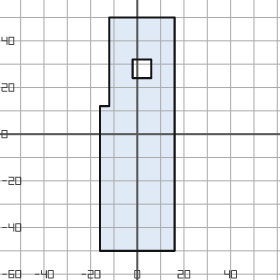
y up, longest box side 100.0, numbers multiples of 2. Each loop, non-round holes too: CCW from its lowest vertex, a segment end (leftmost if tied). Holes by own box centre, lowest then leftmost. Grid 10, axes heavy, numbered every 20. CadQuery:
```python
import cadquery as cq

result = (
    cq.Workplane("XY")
    .moveTo(-16.0, -50.0)
    .lineTo(16.0, -50.0)
    .lineTo(16.0, 50.0)
    .lineTo(-12.0, 50.0)
    .lineTo(-12.0, 12.0)
    .lineTo(-16.0, 12.0)
    .close()
    .moveTo(-2.0, 24.0)
    .lineTo(6.0, 24.0)
    .lineTo(6.0, 32.0)
    .lineTo(-2.0, 32.0)
    .close()
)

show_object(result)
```